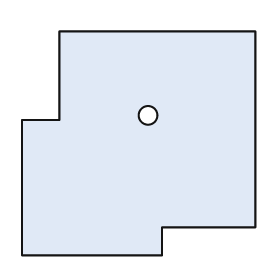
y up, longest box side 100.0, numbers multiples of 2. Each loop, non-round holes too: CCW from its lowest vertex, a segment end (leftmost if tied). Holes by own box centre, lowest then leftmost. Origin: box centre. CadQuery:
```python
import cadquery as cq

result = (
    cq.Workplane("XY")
    .moveTo(-50.0, -48.0)
    .lineTo(10.0, -48.0)
    .lineTo(10.0, -36.0)
    .lineTo(50.0, -36.0)
    .lineTo(50.0, 48.0)
    .lineTo(-34.0, 48.0)
    .lineTo(-34.0, 10.0)
    .lineTo(-50.0, 10.0)
    .close()
    .moveTo(4.0, 12.0)
    .circle(4.0)
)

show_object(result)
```